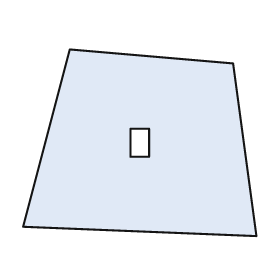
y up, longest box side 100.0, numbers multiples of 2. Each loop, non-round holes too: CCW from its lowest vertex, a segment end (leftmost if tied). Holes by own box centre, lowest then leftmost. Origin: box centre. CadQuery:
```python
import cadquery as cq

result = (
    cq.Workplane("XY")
    .moveTo(50.0, -40.0)
    .lineTo(40.0, 34.0)
    .lineTo(-30.0, 40.0)
    .lineTo(-50.0, -36.0)
    .close()
    .moveTo(-4.0, -6.0)
    .lineTo(4.0, -6.0)
    .lineTo(4.0, 6.0)
    .lineTo(-4.0, 6.0)
    .close()
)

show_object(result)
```